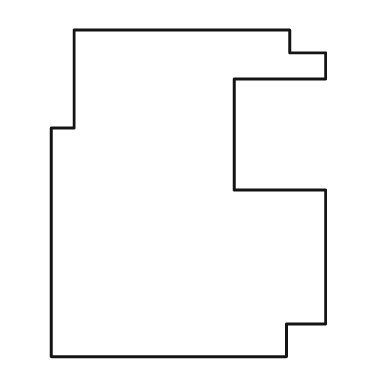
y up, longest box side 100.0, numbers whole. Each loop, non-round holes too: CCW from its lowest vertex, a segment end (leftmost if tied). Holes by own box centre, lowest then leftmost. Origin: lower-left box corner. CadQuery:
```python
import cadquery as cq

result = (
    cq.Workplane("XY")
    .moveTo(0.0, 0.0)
    .lineTo(72.0, 0.0)
    .lineTo(72.0, 10.0)
    .lineTo(84.0, 10.0)
    .lineTo(84.0, 51.0)
    .lineTo(56.0, 51.0)
    .lineTo(56.0, 85.0)
    .lineTo(84.0, 85.0)
    .lineTo(84.0, 93.0)
    .lineTo(73.0, 93.0)
    .lineTo(73.0, 100.0)
    .lineTo(7.0, 100.0)
    .lineTo(7.0, 70.0)
    .lineTo(0.0, 70.0)
    .close()
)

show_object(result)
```